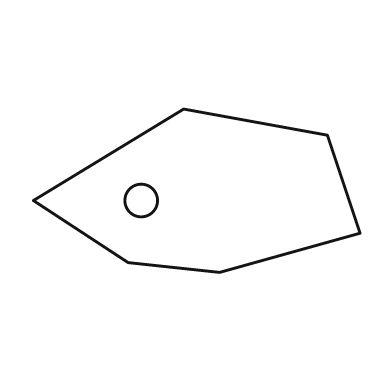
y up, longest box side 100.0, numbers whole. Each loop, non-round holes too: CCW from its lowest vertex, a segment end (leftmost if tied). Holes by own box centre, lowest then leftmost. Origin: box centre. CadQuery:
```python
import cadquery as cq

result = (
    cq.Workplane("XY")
    .moveTo(7.0, -25.0)
    .lineTo(50.0, -13.0)
    .lineTo(40.0, 17.0)
    .lineTo(-4.0, 25.0)
    .lineTo(-50.0, -3.0)
    .lineTo(-21.0, -22.0)
    .close()
    .moveTo(-17.0, -3.0)
    .circle(5.0)
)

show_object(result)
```